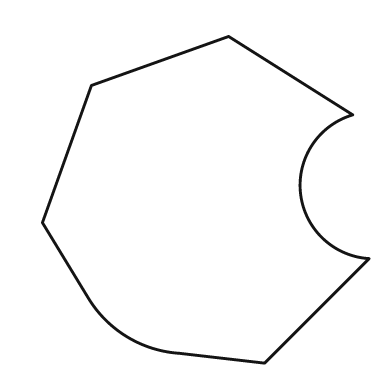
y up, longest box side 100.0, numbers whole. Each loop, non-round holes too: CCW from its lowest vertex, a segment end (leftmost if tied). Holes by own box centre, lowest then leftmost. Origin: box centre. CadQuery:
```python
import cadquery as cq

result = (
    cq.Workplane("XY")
    .moveTo(18.0, -50.0)
    .lineTo(50.0, -18.0)
    .threePointArc((29.0, 2.0), (45.0, 26.0))
    .lineTo(7.0, 50.0)
    .lineTo(-35.0, 35.0)
    .lineTo(-50.0, -7.0)
    .lineTo(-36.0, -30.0)
    .threePointArc((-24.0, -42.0), (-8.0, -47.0))
    .close()
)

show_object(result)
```